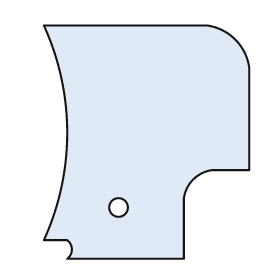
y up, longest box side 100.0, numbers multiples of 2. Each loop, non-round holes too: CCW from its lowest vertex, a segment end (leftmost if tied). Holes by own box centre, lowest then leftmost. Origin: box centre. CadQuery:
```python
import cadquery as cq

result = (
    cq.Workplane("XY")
    .moveTo(-34.0, -50.0)
    .lineTo(16.0, -50.0)
    .lineTo(16.0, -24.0)
    .threePointArc((20.0, -16.0), (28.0, -12.0))
    .lineTo(44.0, -12.0)
    .lineTo(44.0, 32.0)
    .threePointArc((38.0, 44.0), (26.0, 50.0))
    .lineTo(-44.0, 50.0)
    .threePointArc((-34.0, 4.0), (-44.0, -42.0))
    .lineTo(-34.0, -42.0)
    .threePointArc((-32.0, -46.0), (-34.0, -50.0))
    .close()
    .moveTo(-12.0, -28.0)
    .circle(4.0)
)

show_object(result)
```